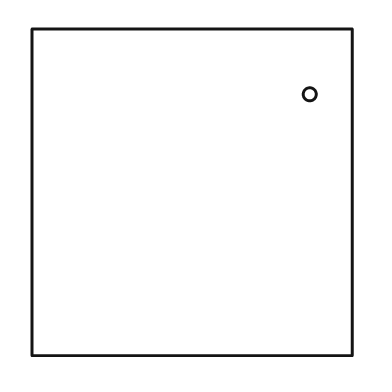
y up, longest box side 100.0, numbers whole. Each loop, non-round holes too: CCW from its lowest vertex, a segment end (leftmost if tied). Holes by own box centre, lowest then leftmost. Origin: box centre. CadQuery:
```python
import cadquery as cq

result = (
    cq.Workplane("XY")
    .moveTo(-49.0, -50.0)
    .lineTo(49.0, -50.0)
    .lineTo(49.0, 50.0)
    .lineTo(-49.0, 50.0)
    .close()
    .moveTo(36.0, 30.0)
    .circle(2.0)
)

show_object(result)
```